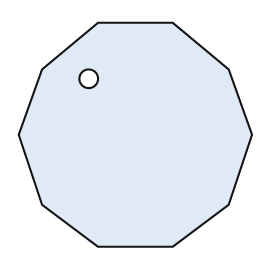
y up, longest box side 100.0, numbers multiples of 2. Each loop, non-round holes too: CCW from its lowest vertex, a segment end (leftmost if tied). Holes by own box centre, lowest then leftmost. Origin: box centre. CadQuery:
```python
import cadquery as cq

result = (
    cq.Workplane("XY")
    .moveTo(-16.0, -48.0)
    .lineTo(16.0, -48.0)
    .lineTo(40.0, -30.0)
    .lineTo(50.0, 0.0)
    .lineTo(40.0, 28.0)
    .lineTo(16.0, 48.0)
    .lineTo(-16.0, 48.0)
    .lineTo(-40.0, 28.0)
    .lineTo(-50.0, 0.0)
    .lineTo(-40.0, -30.0)
    .close()
    .moveTo(-20.0, 24.0)
    .circle(4.0)
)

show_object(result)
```